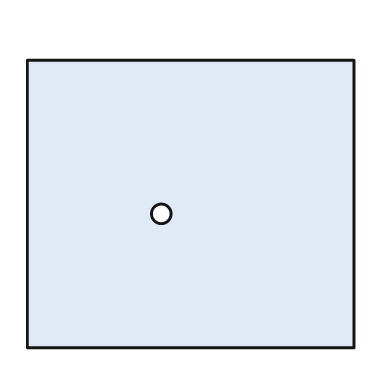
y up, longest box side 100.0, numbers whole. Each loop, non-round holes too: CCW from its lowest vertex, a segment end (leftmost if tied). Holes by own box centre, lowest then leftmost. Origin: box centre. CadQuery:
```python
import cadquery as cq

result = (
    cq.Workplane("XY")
    .moveTo(-50.0, -44.0)
    .lineTo(50.0, -44.0)
    .lineTo(50.0, 44.0)
    .lineTo(-50.0, 44.0)
    .close()
    .moveTo(-9.0, -3.0)
    .circle(3.0)
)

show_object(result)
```